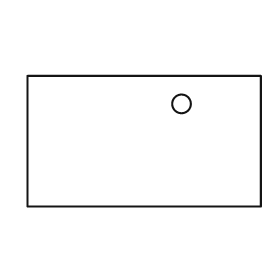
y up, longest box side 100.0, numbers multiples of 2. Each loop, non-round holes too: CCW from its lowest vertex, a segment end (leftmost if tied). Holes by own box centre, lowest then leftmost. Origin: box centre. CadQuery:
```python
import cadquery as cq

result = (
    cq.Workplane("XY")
    .moveTo(-50.0, -28.0)
    .lineTo(50.0, -28.0)
    .lineTo(50.0, 28.0)
    .lineTo(-50.0, 28.0)
    .close()
    .moveTo(16.0, 16.0)
    .circle(4.0)
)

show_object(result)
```